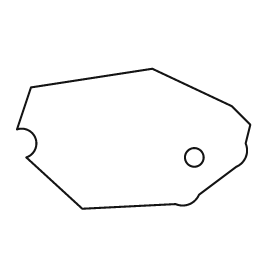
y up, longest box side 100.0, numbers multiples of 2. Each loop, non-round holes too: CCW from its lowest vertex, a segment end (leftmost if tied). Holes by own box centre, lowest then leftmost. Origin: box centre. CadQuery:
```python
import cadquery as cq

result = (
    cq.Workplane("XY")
    .moveTo(-22.0, -30.0)
    .lineTo(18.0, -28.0)
    .threePointArc((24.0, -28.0), (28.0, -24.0))
    .lineTo(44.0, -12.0)
    .threePointArc((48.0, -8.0), (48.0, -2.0))
    .lineTo(50.0, 6.0)
    .lineTo(42.0, 14.0)
    .lineTo(8.0, 30.0)
    .lineTo(-44.0, 22.0)
    .lineTo(-50.0, 4.0)
    .threePointArc((-42.0, 0.0), (-46.0, -8.0))
    .close()
    .moveTo(26.0, -8.0)
    .circle(4.0)
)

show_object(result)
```